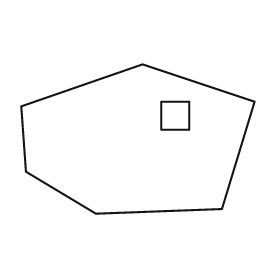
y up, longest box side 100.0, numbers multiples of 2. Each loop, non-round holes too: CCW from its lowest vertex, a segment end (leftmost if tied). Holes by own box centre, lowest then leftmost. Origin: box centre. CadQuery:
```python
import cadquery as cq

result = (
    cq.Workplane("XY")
    .moveTo(-18.0, -32.0)
    .lineTo(36.0, -30.0)
    .lineTo(50.0, 16.0)
    .lineTo(2.0, 32.0)
    .lineTo(-50.0, 14.0)
    .lineTo(-48.0, -14.0)
    .close()
    .moveTo(10.0, 4.0)
    .lineTo(22.0, 4.0)
    .lineTo(22.0, 16.0)
    .lineTo(10.0, 16.0)
    .close()
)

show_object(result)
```